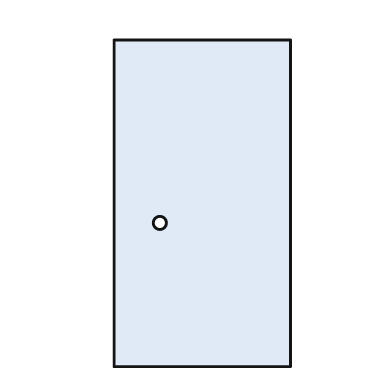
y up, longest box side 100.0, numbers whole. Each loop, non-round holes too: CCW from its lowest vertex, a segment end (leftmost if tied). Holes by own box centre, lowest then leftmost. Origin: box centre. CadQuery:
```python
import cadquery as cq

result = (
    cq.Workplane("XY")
    .moveTo(-27.0, -50.0)
    .lineTo(27.0, -50.0)
    .lineTo(27.0, 50.0)
    .lineTo(-27.0, 50.0)
    .close()
    .moveTo(-13.0, -6.0)
    .circle(2.0)
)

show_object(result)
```